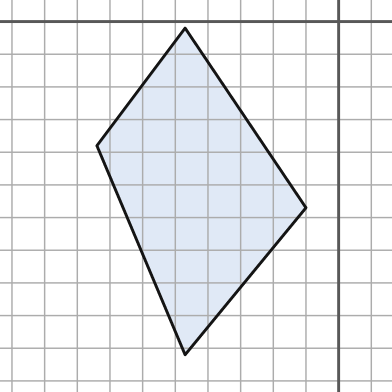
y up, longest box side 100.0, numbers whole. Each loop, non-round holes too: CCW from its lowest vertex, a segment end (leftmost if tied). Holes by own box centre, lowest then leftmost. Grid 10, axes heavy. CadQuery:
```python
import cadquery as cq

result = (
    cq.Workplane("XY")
    .moveTo(-47.0, -102.0)
    .lineTo(-10.0, -57.0)
    .lineTo(-47.0, -2.0)
    .lineTo(-74.0, -38.0)
    .close()
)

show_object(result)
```